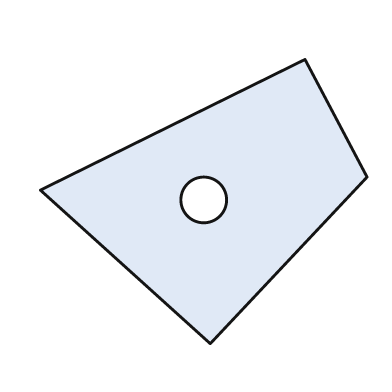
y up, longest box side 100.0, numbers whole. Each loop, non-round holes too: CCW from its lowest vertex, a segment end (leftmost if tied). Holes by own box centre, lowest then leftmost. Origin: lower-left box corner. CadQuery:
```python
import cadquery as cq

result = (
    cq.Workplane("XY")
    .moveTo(52.0, 0.0)
    .lineTo(100.0, 51.0)
    .lineTo(81.0, 87.0)
    .lineTo(0.0, 47.0)
    .close()
    .moveTo(50.0, 44.0)
    .circle(7.0)
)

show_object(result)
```